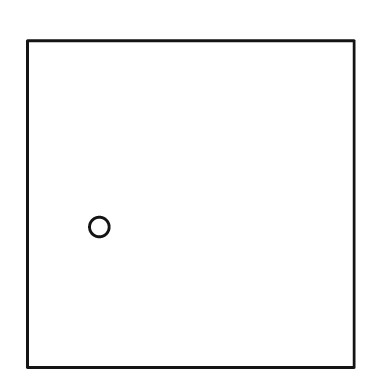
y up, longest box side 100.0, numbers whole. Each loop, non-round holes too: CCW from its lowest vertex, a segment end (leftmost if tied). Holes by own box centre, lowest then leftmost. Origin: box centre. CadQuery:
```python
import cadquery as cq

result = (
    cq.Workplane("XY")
    .moveTo(-50.0, -50.0)
    .lineTo(50.0, -50.0)
    .lineTo(50.0, 50.0)
    .lineTo(-50.0, 50.0)
    .close()
    .moveTo(-28.0, -7.0)
    .circle(3.0)
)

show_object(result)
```